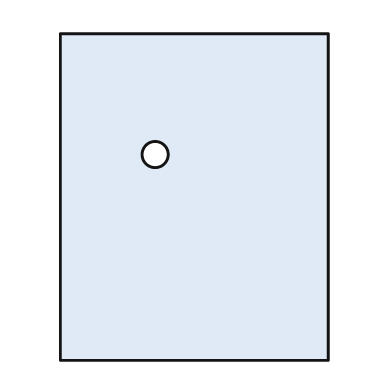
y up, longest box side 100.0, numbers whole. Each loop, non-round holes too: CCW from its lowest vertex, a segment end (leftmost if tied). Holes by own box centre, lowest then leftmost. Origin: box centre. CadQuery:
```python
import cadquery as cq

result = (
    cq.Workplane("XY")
    .moveTo(-41.0, -50.0)
    .lineTo(41.0, -50.0)
    .lineTo(41.0, 50.0)
    .lineTo(-41.0, 50.0)
    .close()
    .moveTo(-12.0, 13.0)
    .circle(4.0)
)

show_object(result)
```